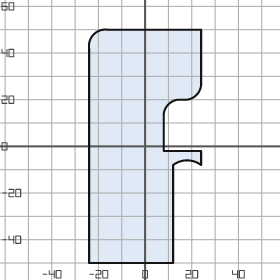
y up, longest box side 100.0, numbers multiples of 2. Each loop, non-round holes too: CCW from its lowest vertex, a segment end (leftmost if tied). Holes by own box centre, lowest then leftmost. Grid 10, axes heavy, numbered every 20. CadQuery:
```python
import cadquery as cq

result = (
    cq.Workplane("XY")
    .moveTo(-24.0, -50.0)
    .lineTo(12.0, -50.0)
    .lineTo(12.0, -8.0)
    .threePointArc((18.0, -6.0), (24.0, -8.0))
    .lineTo(24.0, -2.0)
    .lineTo(8.0, -2.0)
    .lineTo(8.0, 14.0)
    .threePointArc((10.0, 18.0), (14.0, 20.0))
    .lineTo(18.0, 20.0)
    .threePointArc((22.0, 22.0), (24.0, 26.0))
    .lineTo(24.0, 50.0)
    .lineTo(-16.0, 50.0)
    .threePointArc((-22.0, 48.0), (-24.0, 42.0))
    .close()
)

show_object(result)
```